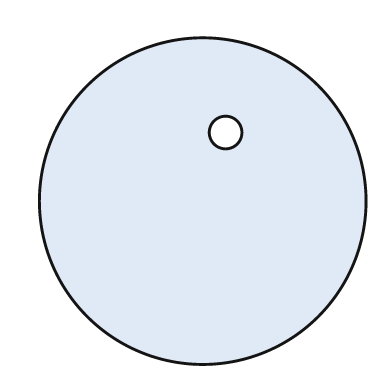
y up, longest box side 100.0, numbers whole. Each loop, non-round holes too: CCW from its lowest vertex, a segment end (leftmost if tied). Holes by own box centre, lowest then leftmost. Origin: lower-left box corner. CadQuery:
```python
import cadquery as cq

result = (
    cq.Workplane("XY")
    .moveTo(50.0, 50.0)
    .circle(50.0)
    .moveTo(57.0, 71.0)
    .circle(5.0)
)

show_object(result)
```